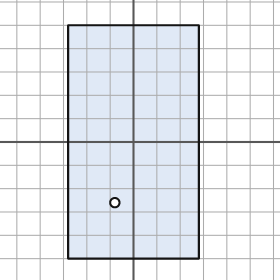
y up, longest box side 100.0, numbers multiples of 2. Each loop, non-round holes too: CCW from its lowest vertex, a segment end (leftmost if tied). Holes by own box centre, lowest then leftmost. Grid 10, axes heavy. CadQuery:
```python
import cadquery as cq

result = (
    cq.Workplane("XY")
    .moveTo(-28.0, -50.0)
    .lineTo(28.0, -50.0)
    .lineTo(28.0, 50.0)
    .lineTo(-28.0, 50.0)
    .close()
    .moveTo(-8.0, -26.0)
    .circle(2.0)
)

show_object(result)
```